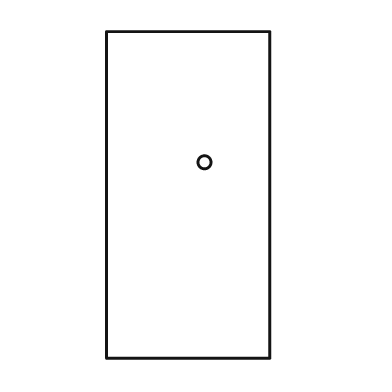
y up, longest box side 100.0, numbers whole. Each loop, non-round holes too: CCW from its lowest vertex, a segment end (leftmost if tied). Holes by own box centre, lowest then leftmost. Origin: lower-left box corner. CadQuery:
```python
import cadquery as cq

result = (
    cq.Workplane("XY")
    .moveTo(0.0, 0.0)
    .lineTo(50.0, 0.0)
    .lineTo(50.0, 100.0)
    .lineTo(0.0, 100.0)
    .close()
    .moveTo(30.0, 60.0)
    .circle(2.0)
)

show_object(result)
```